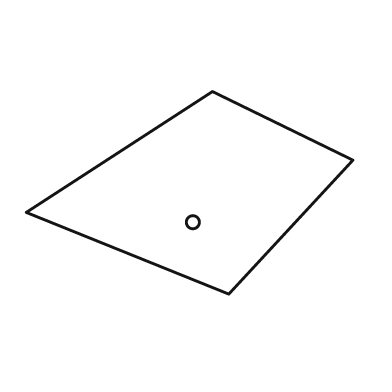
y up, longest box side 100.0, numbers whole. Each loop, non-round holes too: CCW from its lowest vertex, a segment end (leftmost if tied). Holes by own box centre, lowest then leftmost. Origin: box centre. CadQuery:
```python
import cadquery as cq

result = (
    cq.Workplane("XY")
    .moveTo(12.0, -31.0)
    .lineTo(50.0, 10.0)
    .lineTo(7.0, 31.0)
    .lineTo(-50.0, -6.0)
    .close()
    .moveTo(1.0, -9.0)
    .circle(2.0)
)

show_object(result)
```